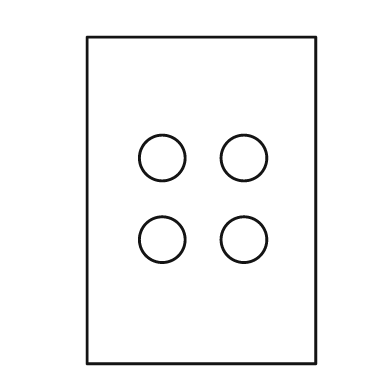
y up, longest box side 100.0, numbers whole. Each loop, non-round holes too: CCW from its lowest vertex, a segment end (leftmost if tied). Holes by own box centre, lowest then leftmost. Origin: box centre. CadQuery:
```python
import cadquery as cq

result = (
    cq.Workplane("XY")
    .moveTo(-35.0, -50.0)
    .lineTo(35.0, -50.0)
    .lineTo(35.0, 50.0)
    .lineTo(-35.0, 50.0)
    .close()
    .moveTo(-12.0, -12.0)
    .circle(7.0)
    .moveTo(13.0, -12.0)
    .circle(7.0)
    .moveTo(-12.0, 13.0)
    .circle(7.0)
    .moveTo(13.0, 13.0)
    .circle(7.0)
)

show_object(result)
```